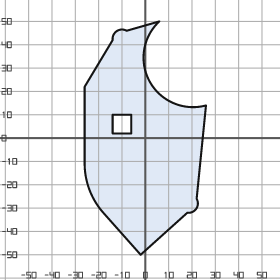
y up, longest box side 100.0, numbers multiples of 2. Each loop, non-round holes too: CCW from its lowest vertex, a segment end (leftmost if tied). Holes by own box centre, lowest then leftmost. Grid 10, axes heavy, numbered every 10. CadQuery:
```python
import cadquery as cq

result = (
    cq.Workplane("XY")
    .moveTo(-2.0, -50.0)
    .lineTo(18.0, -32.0)
    .threePointArc((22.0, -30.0), (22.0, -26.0))
    .lineTo(26.0, 14.0)
    .threePointArc((2.0, 24.0), (6.0, 50.0))
    .lineTo(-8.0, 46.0)
    .threePointArc((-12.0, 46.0), (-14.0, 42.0))
    .lineTo(-26.0, 22.0)
    .lineTo(-26.0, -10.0)
    .threePointArc((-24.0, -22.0), (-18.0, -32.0))
    .close()
    .moveTo(-14.0, 2.0)
    .lineTo(-6.0, 2.0)
    .lineTo(-6.0, 10.0)
    .lineTo(-14.0, 10.0)
    .close()
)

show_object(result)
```